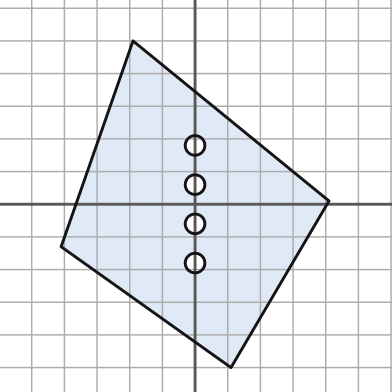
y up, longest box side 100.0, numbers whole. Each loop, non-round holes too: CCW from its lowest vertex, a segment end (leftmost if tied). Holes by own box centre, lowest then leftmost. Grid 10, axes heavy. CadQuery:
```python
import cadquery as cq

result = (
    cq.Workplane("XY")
    .moveTo(11.0, -50.0)
    .lineTo(41.0, 1.0)
    .lineTo(-19.0, 50.0)
    .lineTo(-41.0, -13.0)
    .close()
    .moveTo(0.0, -18.0)
    .circle(3.0)
    .moveTo(0.0, -6.0)
    .circle(3.0)
    .moveTo(0.0, 6.0)
    .circle(3.0)
    .moveTo(0.0, 18.0)
    .circle(3.0)
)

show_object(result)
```